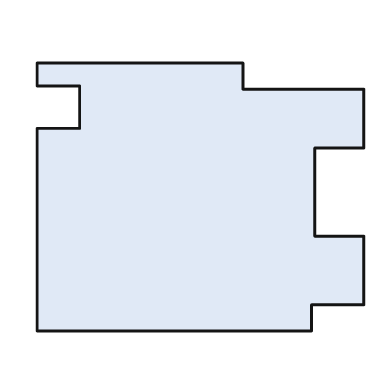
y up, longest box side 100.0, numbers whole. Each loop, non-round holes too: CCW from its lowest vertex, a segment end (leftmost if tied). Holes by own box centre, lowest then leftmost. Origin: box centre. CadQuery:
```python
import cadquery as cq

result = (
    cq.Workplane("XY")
    .moveTo(-50.0, -41.0)
    .lineTo(34.0, -41.0)
    .lineTo(34.0, -33.0)
    .lineTo(50.0, -33.0)
    .lineTo(50.0, -12.0)
    .lineTo(35.0, -12.0)
    .lineTo(35.0, 15.0)
    .lineTo(50.0, 15.0)
    .lineTo(50.0, 33.0)
    .lineTo(13.0, 33.0)
    .lineTo(13.0, 41.0)
    .lineTo(-50.0, 41.0)
    .lineTo(-50.0, 34.0)
    .lineTo(-37.0, 34.0)
    .lineTo(-37.0, 21.0)
    .lineTo(-50.0, 21.0)
    .close()
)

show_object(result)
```